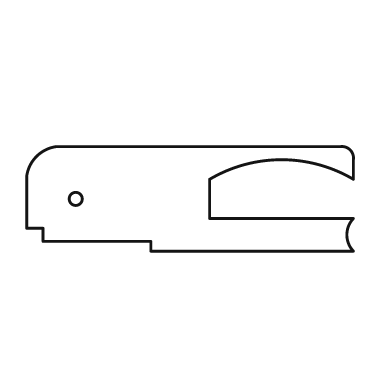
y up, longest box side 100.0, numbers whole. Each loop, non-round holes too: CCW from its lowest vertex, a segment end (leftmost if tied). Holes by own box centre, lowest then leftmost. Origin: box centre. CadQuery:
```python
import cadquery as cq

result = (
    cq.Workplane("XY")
    .moveTo(-12.0, -16.0)
    .lineTo(50.0, -16.0)
    .threePointArc((48.0, -11.0), (50.0, -6.0))
    .lineTo(6.0, -6.0)
    .lineTo(6.0, 6.0)
    .threePointArc((28.0, 12.0), (50.0, 6.0))
    .lineTo(50.0, 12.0)
    .threePointArc((49.0, 15.0), (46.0, 16.0))
    .lineTo(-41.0, 16.0)
    .threePointArc((-47.0, 13.0), (-50.0, 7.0))
    .lineTo(-50.0, -9.0)
    .lineTo(-45.0, -9.0)
    .lineTo(-45.0, -13.0)
    .lineTo(-12.0, -13.0)
    .close()
    .moveTo(-35.0, 0.0)
    .circle(2.0)
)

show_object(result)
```